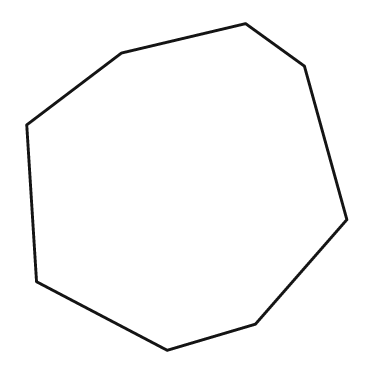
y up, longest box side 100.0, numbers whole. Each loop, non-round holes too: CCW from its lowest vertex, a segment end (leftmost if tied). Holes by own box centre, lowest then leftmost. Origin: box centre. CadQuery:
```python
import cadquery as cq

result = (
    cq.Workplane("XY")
    .moveTo(-6.0, -50.0)
    .lineTo(21.0, -42.0)
    .lineTo(49.0, -10.0)
    .lineTo(36.0, 37.0)
    .lineTo(18.0, 50.0)
    .lineTo(-20.0, 41.0)
    .lineTo(-49.0, 19.0)
    .lineTo(-46.0, -29.0)
    .close()
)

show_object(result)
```